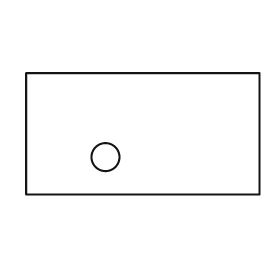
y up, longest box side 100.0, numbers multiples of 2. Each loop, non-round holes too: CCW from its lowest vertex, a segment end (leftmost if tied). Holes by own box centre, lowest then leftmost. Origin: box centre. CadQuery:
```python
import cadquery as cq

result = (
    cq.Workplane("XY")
    .moveTo(-50.0, -26.0)
    .lineTo(50.0, -26.0)
    .lineTo(50.0, 26.0)
    .lineTo(-50.0, 26.0)
    .close()
    .moveTo(-16.0, -10.0)
    .circle(6.0)
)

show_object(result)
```